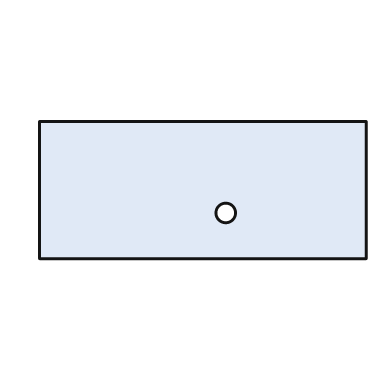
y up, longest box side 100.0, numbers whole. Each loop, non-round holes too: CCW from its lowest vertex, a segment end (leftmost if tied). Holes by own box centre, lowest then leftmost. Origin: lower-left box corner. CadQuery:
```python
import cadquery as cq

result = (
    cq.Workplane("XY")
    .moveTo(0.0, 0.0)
    .lineTo(100.0, 0.0)
    .lineTo(100.0, 42.0)
    .lineTo(0.0, 42.0)
    .close()
    .moveTo(57.0, 14.0)
    .circle(3.0)
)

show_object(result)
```